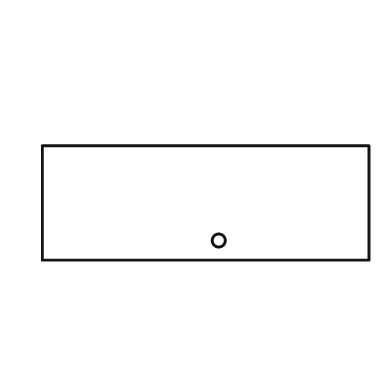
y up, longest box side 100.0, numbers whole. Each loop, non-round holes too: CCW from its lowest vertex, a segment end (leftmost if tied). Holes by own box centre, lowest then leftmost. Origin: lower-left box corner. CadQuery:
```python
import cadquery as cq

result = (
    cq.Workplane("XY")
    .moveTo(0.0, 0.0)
    .lineTo(100.0, 0.0)
    .lineTo(100.0, 35.0)
    .lineTo(0.0, 35.0)
    .close()
    .moveTo(54.0, 6.0)
    .circle(2.0)
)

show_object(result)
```